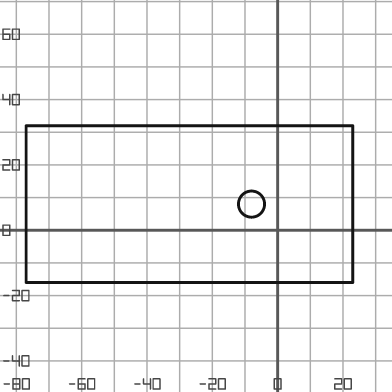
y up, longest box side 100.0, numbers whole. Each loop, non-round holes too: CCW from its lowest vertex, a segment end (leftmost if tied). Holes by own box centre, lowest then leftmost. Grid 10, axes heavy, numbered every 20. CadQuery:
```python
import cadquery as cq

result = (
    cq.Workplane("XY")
    .moveTo(-77.0, -16.0)
    .lineTo(23.0, -16.0)
    .lineTo(23.0, 32.0)
    .lineTo(-77.0, 32.0)
    .close()
    .moveTo(-8.0, 8.0)
    .circle(4.0)
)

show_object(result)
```